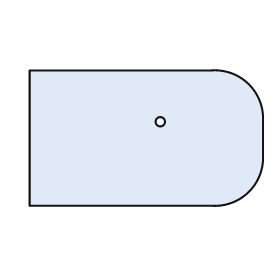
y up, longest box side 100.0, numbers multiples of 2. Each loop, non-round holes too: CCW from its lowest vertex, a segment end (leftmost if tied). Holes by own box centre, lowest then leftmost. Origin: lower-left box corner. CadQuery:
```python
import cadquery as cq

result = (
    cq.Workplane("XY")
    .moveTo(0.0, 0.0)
    .lineTo(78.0, 0.0)
    .threePointArc((94.0, 6.0), (100.0, 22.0))
    .lineTo(100.0, 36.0)
    .threePointArc((94.0, 52.0), (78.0, 58.0))
    .lineTo(0.0, 58.0)
    .close()
    .moveTo(56.0, 36.0)
    .circle(2.0)
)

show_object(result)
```